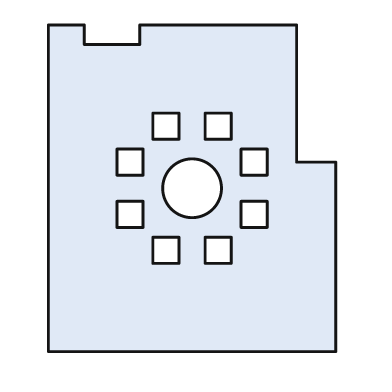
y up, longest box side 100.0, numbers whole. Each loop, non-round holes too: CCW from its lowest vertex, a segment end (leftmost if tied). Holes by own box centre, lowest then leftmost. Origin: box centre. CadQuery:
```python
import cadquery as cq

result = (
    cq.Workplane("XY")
    .moveTo(-44.0, -50.0)
    .lineTo(44.0, -50.0)
    .lineTo(44.0, 8.0)
    .lineTo(32.0, 8.0)
    .lineTo(32.0, 50.0)
    .lineTo(-16.0, 50.0)
    .lineTo(-16.0, 44.0)
    .lineTo(-33.0, 44.0)
    .lineTo(-33.0, 50.0)
    .lineTo(-44.0, 50.0)
    .close()
    .moveTo(-12.0, -23.0)
    .lineTo(-4.0, -23.0)
    .lineTo(-4.0, -15.0)
    .lineTo(-12.0, -15.0)
    .close()
    .moveTo(4.0, -23.0)
    .lineTo(12.0, -23.0)
    .lineTo(12.0, -15.0)
    .lineTo(4.0, -15.0)
    .close()
    .moveTo(-23.0, -12.0)
    .lineTo(-15.0, -12.0)
    .lineTo(-15.0, -4.0)
    .lineTo(-23.0, -4.0)
    .close()
    .moveTo(15.0, -12.0)
    .lineTo(23.0, -12.0)
    .lineTo(23.0, -4.0)
    .lineTo(15.0, -4.0)
    .close()
    .moveTo(0.0, 0.0)
    .circle(9.0)
    .moveTo(-23.0, 4.0)
    .lineTo(-15.0, 4.0)
    .lineTo(-15.0, 12.0)
    .lineTo(-23.0, 12.0)
    .close()
    .moveTo(15.0, 4.0)
    .lineTo(23.0, 4.0)
    .lineTo(23.0, 12.0)
    .lineTo(15.0, 12.0)
    .close()
    .moveTo(-12.0, 15.0)
    .lineTo(-4.0, 15.0)
    .lineTo(-4.0, 23.0)
    .lineTo(-12.0, 23.0)
    .close()
    .moveTo(4.0, 15.0)
    .lineTo(12.0, 15.0)
    .lineTo(12.0, 23.0)
    .lineTo(4.0, 23.0)
    .close()
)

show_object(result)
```